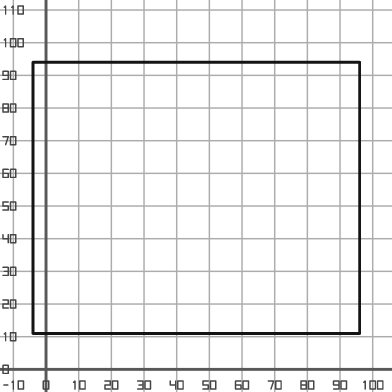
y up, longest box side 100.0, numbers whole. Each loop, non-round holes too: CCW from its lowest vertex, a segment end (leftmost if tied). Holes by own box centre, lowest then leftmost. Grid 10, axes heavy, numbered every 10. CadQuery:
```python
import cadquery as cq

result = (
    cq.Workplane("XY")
    .moveTo(-4.0, 11.0)
    .lineTo(96.0, 11.0)
    .lineTo(96.0, 94.0)
    .lineTo(-4.0, 94.0)
    .close()
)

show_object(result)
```